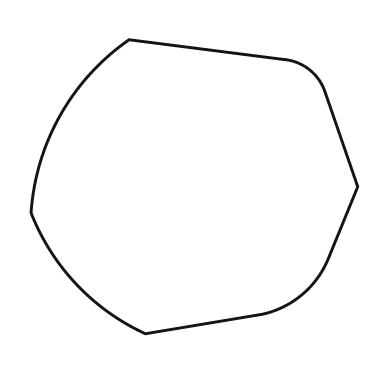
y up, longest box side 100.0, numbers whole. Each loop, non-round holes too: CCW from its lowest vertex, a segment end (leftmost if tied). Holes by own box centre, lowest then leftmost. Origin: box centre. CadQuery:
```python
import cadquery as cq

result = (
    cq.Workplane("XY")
    .moveTo(-15.0, -45.0)
    .lineTo(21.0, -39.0)
    .threePointArc((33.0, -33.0), (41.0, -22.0))
    .lineTo(50.0, 0.0)
    .lineTo(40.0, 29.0)
    .threePointArc((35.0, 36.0), (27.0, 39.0))
    .lineTo(-20.0, 45.0)
    .threePointArc((-41.0, 22.0), (-50.0, -8.0))
    .threePointArc((-36.0, -30.0), (-15.0, -45.0))
    .close()
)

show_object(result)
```